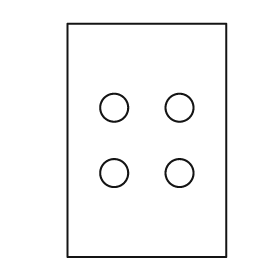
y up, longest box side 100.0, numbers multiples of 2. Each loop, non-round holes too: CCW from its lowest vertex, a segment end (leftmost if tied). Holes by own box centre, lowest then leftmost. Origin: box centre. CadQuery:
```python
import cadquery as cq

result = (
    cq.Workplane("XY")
    .moveTo(-34.0, -50.0)
    .lineTo(34.0, -50.0)
    .lineTo(34.0, 50.0)
    .lineTo(-34.0, 50.0)
    .close()
    .moveTo(-14.0, -14.0)
    .circle(6.0)
    .moveTo(14.0, -14.0)
    .circle(6.0)
    .moveTo(-14.0, 14.0)
    .circle(6.0)
    .moveTo(14.0, 14.0)
    .circle(6.0)
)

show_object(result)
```